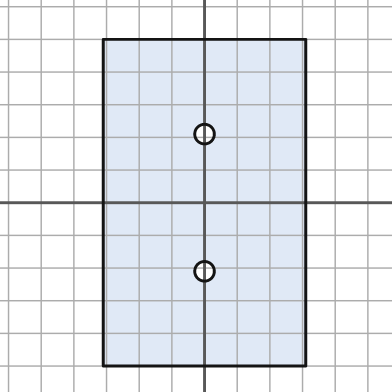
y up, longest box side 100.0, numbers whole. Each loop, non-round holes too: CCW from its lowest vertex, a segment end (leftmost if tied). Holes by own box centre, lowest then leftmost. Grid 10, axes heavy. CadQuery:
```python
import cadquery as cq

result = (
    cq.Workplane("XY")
    .moveTo(-31.0, -50.0)
    .lineTo(31.0, -50.0)
    .lineTo(31.0, 50.0)
    .lineTo(-31.0, 50.0)
    .close()
    .moveTo(0.0, -21.0)
    .circle(3.0)
    .moveTo(0.0, 21.0)
    .circle(3.0)
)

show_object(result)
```